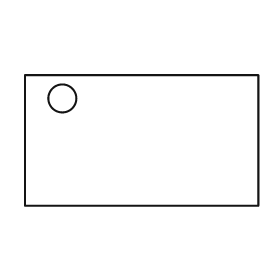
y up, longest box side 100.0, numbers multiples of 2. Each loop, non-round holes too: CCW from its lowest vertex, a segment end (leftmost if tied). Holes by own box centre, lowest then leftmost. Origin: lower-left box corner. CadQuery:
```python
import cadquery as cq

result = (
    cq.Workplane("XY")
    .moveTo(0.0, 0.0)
    .lineTo(100.0, 0.0)
    .lineTo(100.0, 56.0)
    .lineTo(0.0, 56.0)
    .close()
    .moveTo(16.0, 46.0)
    .circle(6.0)
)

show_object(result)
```